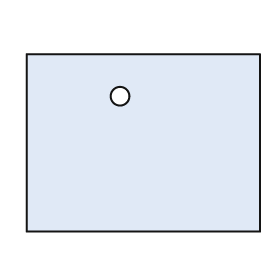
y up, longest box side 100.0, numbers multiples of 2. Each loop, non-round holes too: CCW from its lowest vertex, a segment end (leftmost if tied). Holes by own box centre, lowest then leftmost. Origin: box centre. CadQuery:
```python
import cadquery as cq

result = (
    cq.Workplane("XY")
    .moveTo(-50.0, -38.0)
    .lineTo(50.0, -38.0)
    .lineTo(50.0, 38.0)
    .lineTo(-50.0, 38.0)
    .close()
    .moveTo(-10.0, 20.0)
    .circle(4.0)
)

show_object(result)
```